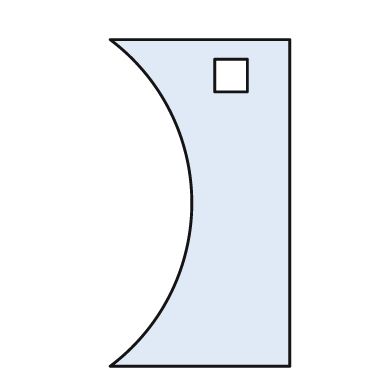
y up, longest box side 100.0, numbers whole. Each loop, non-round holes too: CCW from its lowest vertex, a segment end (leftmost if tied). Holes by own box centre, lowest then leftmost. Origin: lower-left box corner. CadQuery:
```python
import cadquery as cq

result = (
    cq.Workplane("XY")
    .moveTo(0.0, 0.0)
    .lineTo(55.0, 0.0)
    .lineTo(55.0, 100.0)
    .lineTo(0.0, 100.0)
    .threePointArc((25.0, 50.0), (0.0, 0.0))
    .close()
    .moveTo(32.0, 84.0)
    .lineTo(42.0, 84.0)
    .lineTo(42.0, 94.0)
    .lineTo(32.0, 94.0)
    .close()
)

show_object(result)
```